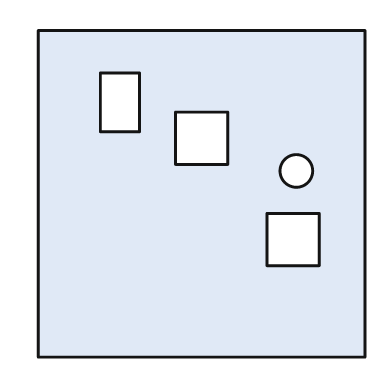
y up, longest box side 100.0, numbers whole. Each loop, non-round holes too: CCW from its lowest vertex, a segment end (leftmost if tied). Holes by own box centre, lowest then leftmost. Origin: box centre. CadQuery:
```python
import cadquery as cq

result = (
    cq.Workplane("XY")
    .moveTo(-50.0, -50.0)
    .lineTo(50.0, -50.0)
    .lineTo(50.0, 50.0)
    .lineTo(-50.0, 50.0)
    .close()
    .moveTo(20.0, -22.0)
    .lineTo(36.0, -22.0)
    .lineTo(36.0, -6.0)
    .lineTo(20.0, -6.0)
    .close()
    .moveTo(29.0, 7.0)
    .circle(5.0)
    .moveTo(-8.0, 9.0)
    .lineTo(8.0, 9.0)
    .lineTo(8.0, 25.0)
    .lineTo(-8.0, 25.0)
    .close()
    .moveTo(-31.0, 19.0)
    .lineTo(-19.0, 19.0)
    .lineTo(-19.0, 37.0)
    .lineTo(-31.0, 37.0)
    .close()
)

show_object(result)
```